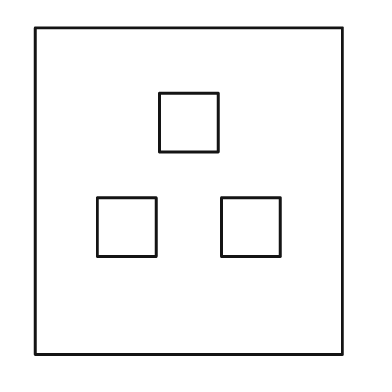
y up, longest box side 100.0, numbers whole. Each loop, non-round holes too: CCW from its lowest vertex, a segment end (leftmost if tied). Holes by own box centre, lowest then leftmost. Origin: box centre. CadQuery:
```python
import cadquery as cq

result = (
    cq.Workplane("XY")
    .moveTo(-47.0, -50.0)
    .lineTo(47.0, -50.0)
    .lineTo(47.0, 50.0)
    .lineTo(-47.0, 50.0)
    .close()
    .moveTo(-28.0, -20.0)
    .lineTo(-10.0, -20.0)
    .lineTo(-10.0, -2.0)
    .lineTo(-28.0, -2.0)
    .close()
    .moveTo(10.0, -20.0)
    .lineTo(28.0, -20.0)
    .lineTo(28.0, -2.0)
    .lineTo(10.0, -2.0)
    .close()
    .moveTo(-9.0, 12.0)
    .lineTo(9.0, 12.0)
    .lineTo(9.0, 30.0)
    .lineTo(-9.0, 30.0)
    .close()
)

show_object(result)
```